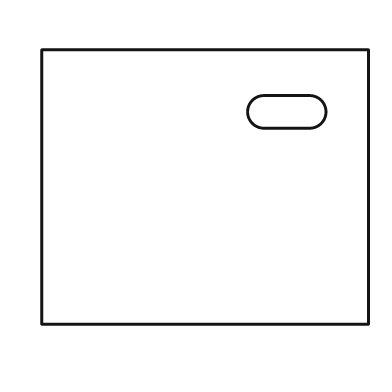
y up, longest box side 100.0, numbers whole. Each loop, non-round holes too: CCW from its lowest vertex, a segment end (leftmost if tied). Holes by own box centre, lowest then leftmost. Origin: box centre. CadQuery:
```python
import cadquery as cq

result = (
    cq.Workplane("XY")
    .moveTo(-50.0, -42.0)
    .lineTo(50.0, -42.0)
    .lineTo(50.0, 42.0)
    .lineTo(-50.0, 42.0)
    .close()
    .moveTo(18.0, 18.0)
    .lineTo(32.0, 18.0)
    .threePointArc((37.0, 23.0), (32.0, 28.0))
    .lineTo(18.0, 28.0)
    .threePointArc((13.0, 23.0), (18.0, 18.0))
    .close()
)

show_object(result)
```